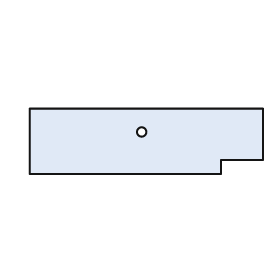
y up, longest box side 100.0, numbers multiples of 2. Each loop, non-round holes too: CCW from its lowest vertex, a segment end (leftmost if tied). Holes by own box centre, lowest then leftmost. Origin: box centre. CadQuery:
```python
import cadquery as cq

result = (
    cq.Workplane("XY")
    .moveTo(-50.0, -14.0)
    .lineTo(32.0, -14.0)
    .lineTo(32.0, -8.0)
    .lineTo(50.0, -8.0)
    .lineTo(50.0, 14.0)
    .lineTo(-50.0, 14.0)
    .close()
    .moveTo(-2.0, 4.0)
    .circle(2.0)
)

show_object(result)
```